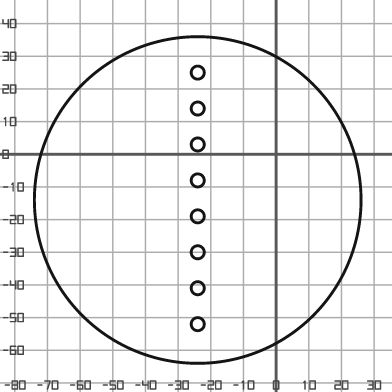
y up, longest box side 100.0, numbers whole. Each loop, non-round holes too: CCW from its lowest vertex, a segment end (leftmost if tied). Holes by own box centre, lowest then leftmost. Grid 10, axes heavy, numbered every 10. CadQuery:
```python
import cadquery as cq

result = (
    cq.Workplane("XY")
    .moveTo(-24.0, -14.0)
    .circle(50.0)
    .moveTo(-24.0, -52.0)
    .circle(2.0)
    .moveTo(-24.0, -41.0)
    .circle(2.0)
    .moveTo(-24.0, -30.0)
    .circle(2.0)
    .moveTo(-24.0, -19.0)
    .circle(2.0)
    .moveTo(-24.0, -8.0)
    .circle(2.0)
    .moveTo(-24.0, 3.0)
    .circle(2.0)
    .moveTo(-24.0, 14.0)
    .circle(2.0)
    .moveTo(-24.0, 25.0)
    .circle(2.0)
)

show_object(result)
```